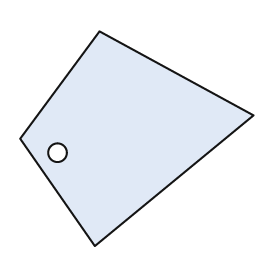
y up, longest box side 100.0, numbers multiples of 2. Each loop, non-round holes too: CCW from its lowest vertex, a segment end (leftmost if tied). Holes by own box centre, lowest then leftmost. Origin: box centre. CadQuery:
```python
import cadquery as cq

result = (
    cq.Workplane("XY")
    .moveTo(-18.0, -46.0)
    .lineTo(50.0, 10.0)
    .lineTo(-16.0, 46.0)
    .lineTo(-50.0, 0.0)
    .close()
    .moveTo(-34.0, -6.0)
    .circle(4.0)
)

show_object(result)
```